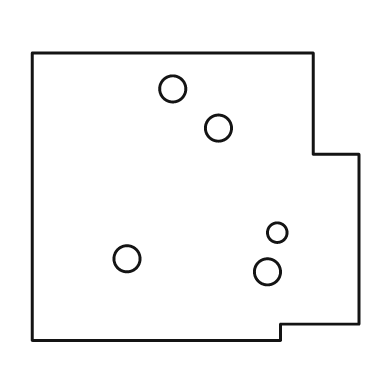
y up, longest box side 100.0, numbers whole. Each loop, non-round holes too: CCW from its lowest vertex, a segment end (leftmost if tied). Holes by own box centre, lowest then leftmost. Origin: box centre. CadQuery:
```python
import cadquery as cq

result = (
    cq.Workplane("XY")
    .moveTo(-50.0, -44.0)
    .lineTo(26.0, -44.0)
    .lineTo(26.0, -39.0)
    .lineTo(50.0, -39.0)
    .lineTo(50.0, 13.0)
    .lineTo(36.0, 13.0)
    .lineTo(36.0, 44.0)
    .lineTo(-50.0, 44.0)
    .close()
    .moveTo(22.0, -23.0)
    .circle(4.0)
    .moveTo(-21.0, -19.0)
    .circle(4.0)
    .moveTo(25.0, -11.0)
    .circle(3.0)
    .moveTo(7.0, 21.0)
    .circle(4.0)
    .moveTo(-7.0, 33.0)
    .circle(4.0)
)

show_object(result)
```